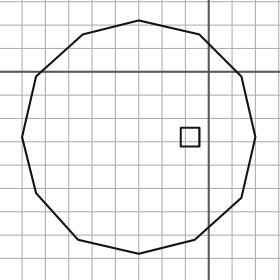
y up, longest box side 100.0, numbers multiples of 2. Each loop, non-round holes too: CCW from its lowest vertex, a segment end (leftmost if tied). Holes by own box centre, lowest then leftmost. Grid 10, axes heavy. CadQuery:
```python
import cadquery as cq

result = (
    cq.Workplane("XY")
    .moveTo(-30.0, -78.0)
    .lineTo(-6.0, -72.0)
    .lineTo(14.0, -54.0)
    .lineTo(20.0, -28.0)
    .lineTo(14.0, -2.0)
    .lineTo(-4.0, 16.0)
    .lineTo(-30.0, 22.0)
    .lineTo(-54.0, 16.0)
    .lineTo(-74.0, -2.0)
    .lineTo(-80.0, -28.0)
    .lineTo(-74.0, -52.0)
    .lineTo(-56.0, -72.0)
    .close()
    .moveTo(-12.0, -32.0)
    .lineTo(-4.0, -32.0)
    .lineTo(-4.0, -24.0)
    .lineTo(-12.0, -24.0)
    .close()
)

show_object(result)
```